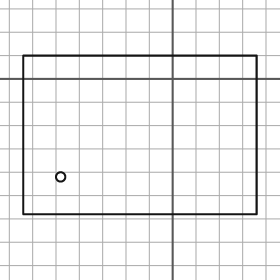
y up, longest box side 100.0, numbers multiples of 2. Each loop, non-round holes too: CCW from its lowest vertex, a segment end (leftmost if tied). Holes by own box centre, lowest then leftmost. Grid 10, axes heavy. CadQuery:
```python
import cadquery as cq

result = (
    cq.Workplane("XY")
    .moveTo(-64.0, -58.0)
    .lineTo(36.0, -58.0)
    .lineTo(36.0, 10.0)
    .lineTo(-64.0, 10.0)
    .close()
    .moveTo(-48.0, -42.0)
    .circle(2.0)
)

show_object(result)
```